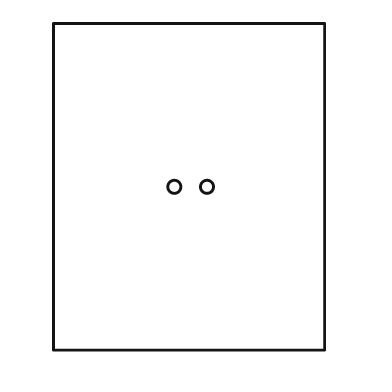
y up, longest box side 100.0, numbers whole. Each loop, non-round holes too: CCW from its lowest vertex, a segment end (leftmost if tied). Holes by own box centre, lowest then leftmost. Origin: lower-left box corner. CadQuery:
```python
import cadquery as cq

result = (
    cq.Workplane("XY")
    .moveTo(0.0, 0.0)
    .lineTo(83.0, 0.0)
    .lineTo(83.0, 100.0)
    .lineTo(0.0, 100.0)
    .close()
    .moveTo(37.0, 50.0)
    .circle(2.0)
    .moveTo(47.0, 50.0)
    .circle(2.0)
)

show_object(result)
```